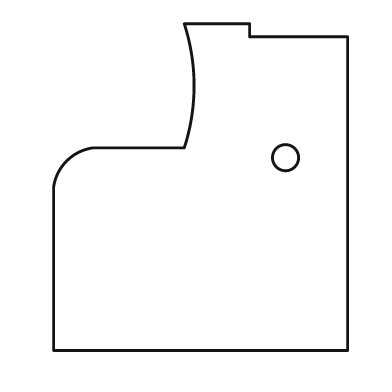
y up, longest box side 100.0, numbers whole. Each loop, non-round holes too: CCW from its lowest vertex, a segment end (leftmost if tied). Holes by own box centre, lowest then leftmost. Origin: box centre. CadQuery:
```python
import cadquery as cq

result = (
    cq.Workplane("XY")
    .moveTo(-45.0, -50.0)
    .lineTo(45.0, -50.0)
    .lineTo(45.0, 46.0)
    .lineTo(15.0, 46.0)
    .lineTo(15.0, 50.0)
    .lineTo(-5.0, 50.0)
    .threePointArc((-2.0, 31.0), (-5.0, 12.0))
    .lineTo(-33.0, 12.0)
    .threePointArc((-41.0, 8.0), (-45.0, 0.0))
    .close()
    .moveTo(26.0, 9.0)
    .circle(4.0)
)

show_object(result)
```